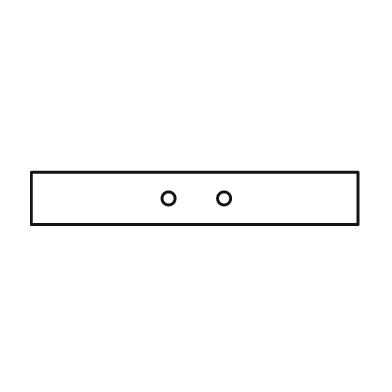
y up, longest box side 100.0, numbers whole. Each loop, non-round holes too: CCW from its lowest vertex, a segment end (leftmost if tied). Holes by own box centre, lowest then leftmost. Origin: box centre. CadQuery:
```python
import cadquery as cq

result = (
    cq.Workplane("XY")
    .moveTo(-50.0, -8.0)
    .lineTo(50.0, -8.0)
    .lineTo(50.0, 8.0)
    .lineTo(-50.0, 8.0)
    .close()
    .moveTo(-8.0, 0.0)
    .circle(2.0)
    .moveTo(9.0, 0.0)
    .circle(2.0)
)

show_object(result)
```